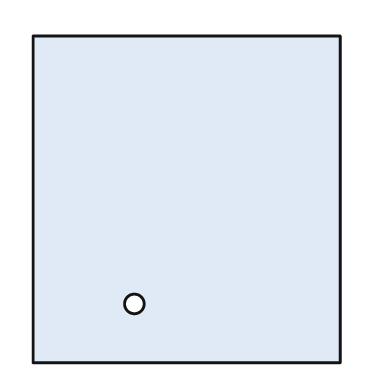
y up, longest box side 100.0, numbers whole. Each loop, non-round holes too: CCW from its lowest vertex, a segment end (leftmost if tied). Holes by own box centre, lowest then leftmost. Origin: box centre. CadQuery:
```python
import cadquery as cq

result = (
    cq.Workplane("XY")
    .moveTo(-47.0, -50.0)
    .lineTo(47.0, -50.0)
    .lineTo(47.0, 50.0)
    .lineTo(-47.0, 50.0)
    .close()
    .moveTo(-16.0, -32.0)
    .circle(3.0)
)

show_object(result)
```